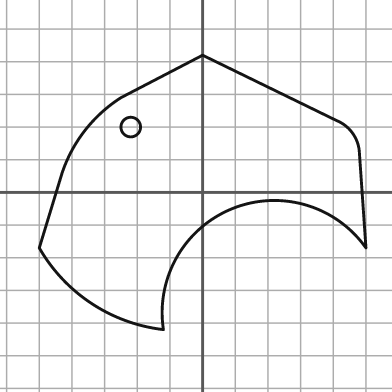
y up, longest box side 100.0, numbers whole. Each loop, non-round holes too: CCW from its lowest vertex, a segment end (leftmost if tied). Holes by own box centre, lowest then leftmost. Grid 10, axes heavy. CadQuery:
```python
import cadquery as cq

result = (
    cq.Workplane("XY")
    .moveTo(-12.0, -42.0)
    .threePointArc((9.0, -5.0), (50.0, -17.0))
    .lineTo(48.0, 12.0)
    .threePointArc((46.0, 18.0), (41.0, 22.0))
    .lineTo(0.0, 42.0)
    .lineTo(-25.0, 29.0)
    .threePointArc((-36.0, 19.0), (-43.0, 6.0))
    .lineTo(-50.0, -17.0)
    .threePointArc((-34.0, -34.0), (-12.0, -42.0))
    .close()
    .moveTo(-22.0, 20.0)
    .circle(3.0)
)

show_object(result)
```